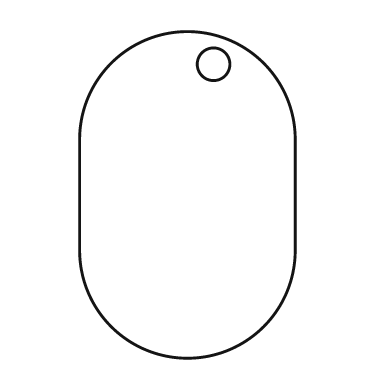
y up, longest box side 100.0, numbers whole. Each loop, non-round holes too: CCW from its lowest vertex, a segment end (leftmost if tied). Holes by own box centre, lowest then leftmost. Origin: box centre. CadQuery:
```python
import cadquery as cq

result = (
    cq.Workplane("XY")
    .moveTo(-33.0, -17.0)
    .threePointArc((0.0, -50.0), (33.0, -17.0))
    .lineTo(33.0, 17.0)
    .threePointArc((0.0, 50.0), (-33.0, 17.0))
    .close()
    .moveTo(8.0, 40.0)
    .circle(5.0)
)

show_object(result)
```